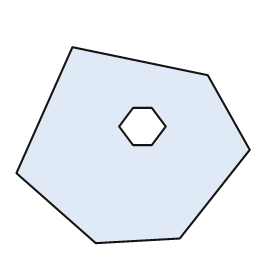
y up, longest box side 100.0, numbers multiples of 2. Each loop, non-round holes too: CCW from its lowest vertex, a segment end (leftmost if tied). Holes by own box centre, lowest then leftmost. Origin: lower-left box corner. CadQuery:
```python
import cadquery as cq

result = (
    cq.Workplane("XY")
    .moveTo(34.0, 0.0)
    .lineTo(70.0, 2.0)
    .lineTo(100.0, 40.0)
    .lineTo(82.0, 72.0)
    .lineTo(24.0, 84.0)
    .lineTo(0.0, 30.0)
    .close()
    .moveTo(50.0, 42.0)
    .lineTo(58.0, 42.0)
    .lineTo(64.0, 50.0)
    .lineTo(58.0, 58.0)
    .lineTo(50.0, 58.0)
    .lineTo(44.0, 50.0)
    .close()
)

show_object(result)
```